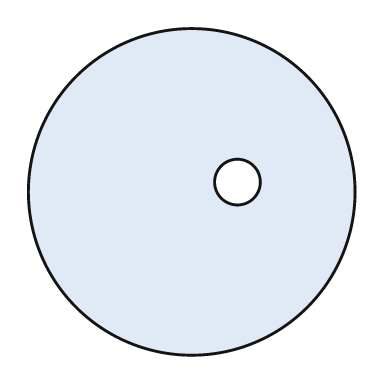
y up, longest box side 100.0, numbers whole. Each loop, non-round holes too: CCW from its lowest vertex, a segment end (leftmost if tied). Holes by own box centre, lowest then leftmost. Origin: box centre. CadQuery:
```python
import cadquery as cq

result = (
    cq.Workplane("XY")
    .moveTo(0.0, 0.0)
    .circle(50.0)
    .moveTo(14.0, 3.0)
    .circle(7.0)
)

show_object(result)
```